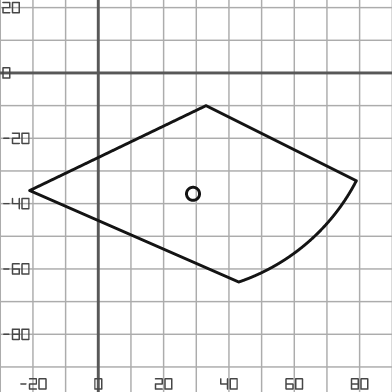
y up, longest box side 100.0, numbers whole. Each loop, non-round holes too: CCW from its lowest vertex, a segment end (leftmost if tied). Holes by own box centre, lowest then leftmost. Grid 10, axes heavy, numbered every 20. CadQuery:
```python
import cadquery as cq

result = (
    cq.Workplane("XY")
    .moveTo(43.0, -64.0)
    .threePointArc((64.0, -52.0), (79.0, -33.0))
    .lineTo(33.0, -10.0)
    .lineTo(-21.0, -36.0)
    .close()
    .moveTo(29.0, -37.0)
    .circle(2.0)
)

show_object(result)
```